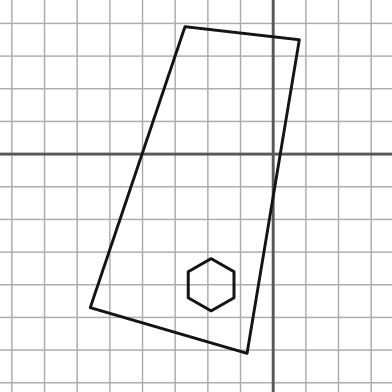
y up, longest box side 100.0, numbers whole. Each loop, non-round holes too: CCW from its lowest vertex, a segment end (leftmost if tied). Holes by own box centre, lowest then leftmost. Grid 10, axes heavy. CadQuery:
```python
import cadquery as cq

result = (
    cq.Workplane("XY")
    .moveTo(-8.0, -61.0)
    .lineTo(8.0, 35.0)
    .lineTo(-27.0, 39.0)
    .lineTo(-56.0, -47.0)
    .close()
    .moveTo(-19.0, -48.0)
    .lineTo(-12.0, -44.0)
    .lineTo(-12.0, -36.0)
    .lineTo(-19.0, -32.0)
    .lineTo(-26.0, -36.0)
    .lineTo(-26.0, -44.0)
    .close()
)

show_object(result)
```